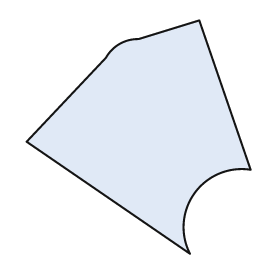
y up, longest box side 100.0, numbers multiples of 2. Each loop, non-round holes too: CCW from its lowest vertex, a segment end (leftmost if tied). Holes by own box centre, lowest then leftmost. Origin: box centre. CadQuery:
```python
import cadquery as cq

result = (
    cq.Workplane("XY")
    .moveTo(22.0, -50.0)
    .threePointArc((24.0, -24.0), (48.0, -14.0))
    .lineTo(26.0, 50.0)
    .lineTo(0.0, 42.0)
    .threePointArc((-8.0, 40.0), (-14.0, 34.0))
    .lineTo(-48.0, -2.0)
    .close()
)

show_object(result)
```